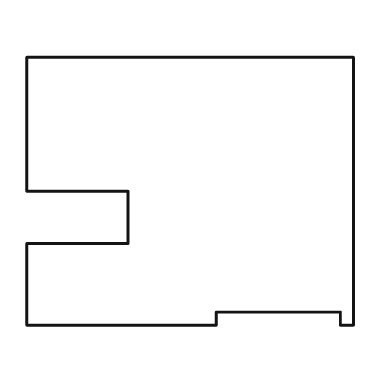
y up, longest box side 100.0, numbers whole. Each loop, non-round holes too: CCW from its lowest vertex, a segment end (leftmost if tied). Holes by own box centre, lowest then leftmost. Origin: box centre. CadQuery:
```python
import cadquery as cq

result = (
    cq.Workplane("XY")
    .moveTo(-50.0, -41.0)
    .lineTo(8.0, -41.0)
    .lineTo(8.0, -37.0)
    .lineTo(46.0, -37.0)
    .lineTo(46.0, -41.0)
    .lineTo(50.0, -41.0)
    .lineTo(50.0, 41.0)
    .lineTo(-50.0, 41.0)
    .lineTo(-50.0, 0.0)
    .lineTo(-19.0, 0.0)
    .lineTo(-19.0, -16.0)
    .lineTo(-50.0, -16.0)
    .close()
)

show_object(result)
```